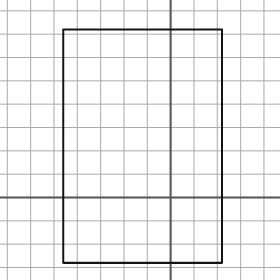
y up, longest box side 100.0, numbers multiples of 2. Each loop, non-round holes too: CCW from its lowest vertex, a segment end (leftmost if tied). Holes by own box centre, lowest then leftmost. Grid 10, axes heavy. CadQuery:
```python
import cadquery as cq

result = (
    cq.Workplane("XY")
    .moveTo(-46.0, -28.0)
    .lineTo(22.0, -28.0)
    .lineTo(22.0, 72.0)
    .lineTo(-46.0, 72.0)
    .close()
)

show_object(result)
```